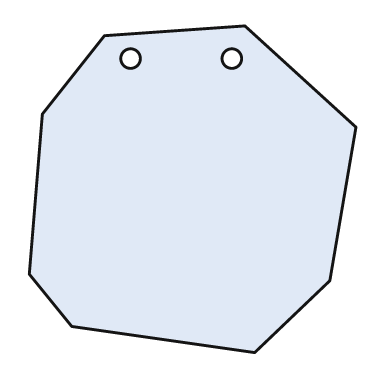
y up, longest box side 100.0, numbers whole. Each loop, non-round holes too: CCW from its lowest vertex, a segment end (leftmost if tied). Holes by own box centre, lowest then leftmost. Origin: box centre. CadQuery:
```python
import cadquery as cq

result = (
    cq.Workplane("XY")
    .moveTo(19.0, -50.0)
    .lineTo(42.0, -28.0)
    .lineTo(50.0, 19.0)
    .lineTo(16.0, 50.0)
    .lineTo(-27.0, 47.0)
    .lineTo(-46.0, 23.0)
    .lineTo(-50.0, -26.0)
    .lineTo(-37.0, -42.0)
    .close()
    .moveTo(-19.0, 40.0)
    .circle(3.0)
    .moveTo(12.0, 40.0)
    .circle(3.0)
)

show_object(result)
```